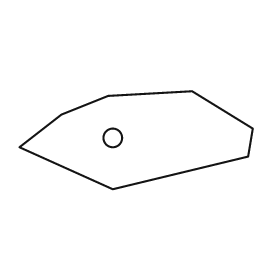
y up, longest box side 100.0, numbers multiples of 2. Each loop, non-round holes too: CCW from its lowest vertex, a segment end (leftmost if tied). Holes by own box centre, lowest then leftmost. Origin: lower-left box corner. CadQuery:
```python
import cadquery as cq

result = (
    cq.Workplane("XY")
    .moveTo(40.0, 0.0)
    .lineTo(98.0, 14.0)
    .lineTo(100.0, 26.0)
    .lineTo(74.0, 42.0)
    .lineTo(38.0, 40.0)
    .lineTo(18.0, 32.0)
    .lineTo(0.0, 18.0)
    .close()
    .moveTo(40.0, 22.0)
    .circle(4.0)
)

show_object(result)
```